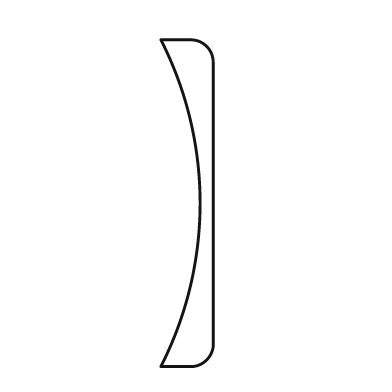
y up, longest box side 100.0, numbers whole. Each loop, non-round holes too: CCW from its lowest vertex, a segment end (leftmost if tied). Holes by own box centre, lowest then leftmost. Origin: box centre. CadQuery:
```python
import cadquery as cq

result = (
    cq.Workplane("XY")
    .moveTo(-8.0, -50.0)
    .lineTo(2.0, -50.0)
    .threePointArc((6.0, -48.0), (8.0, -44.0))
    .lineTo(8.0, 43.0)
    .threePointArc((6.0, 48.0), (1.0, 50.0))
    .lineTo(-8.0, 50.0)
    .threePointArc((4.0, 0.0), (-8.0, -50.0))
    .close()
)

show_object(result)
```